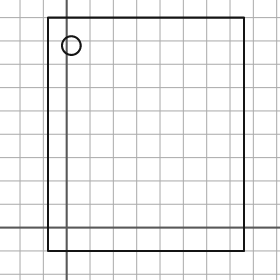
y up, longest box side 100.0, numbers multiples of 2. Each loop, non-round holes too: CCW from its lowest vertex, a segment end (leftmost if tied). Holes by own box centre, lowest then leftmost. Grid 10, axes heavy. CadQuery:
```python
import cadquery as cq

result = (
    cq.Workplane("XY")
    .moveTo(-8.0, -10.0)
    .lineTo(76.0, -10.0)
    .lineTo(76.0, 90.0)
    .lineTo(-8.0, 90.0)
    .close()
    .moveTo(2.0, 78.0)
    .circle(4.0)
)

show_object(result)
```